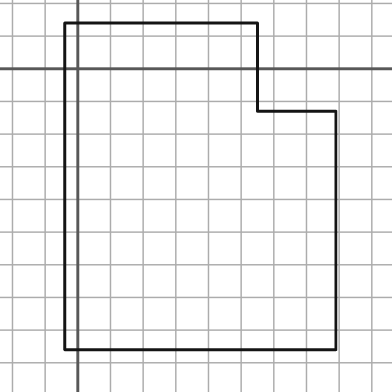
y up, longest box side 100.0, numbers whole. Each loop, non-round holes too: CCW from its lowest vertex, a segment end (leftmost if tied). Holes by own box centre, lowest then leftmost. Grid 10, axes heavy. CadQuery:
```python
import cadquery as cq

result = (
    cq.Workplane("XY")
    .moveTo(-4.0, -86.0)
    .lineTo(79.0, -86.0)
    .lineTo(79.0, -13.0)
    .lineTo(55.0, -13.0)
    .lineTo(55.0, 14.0)
    .lineTo(-4.0, 14.0)
    .close()
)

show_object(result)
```